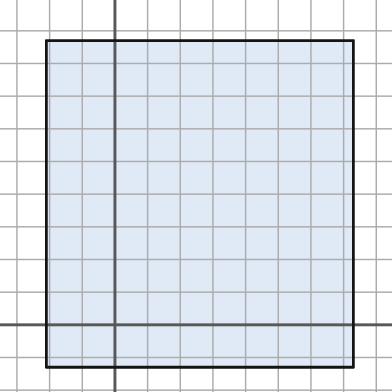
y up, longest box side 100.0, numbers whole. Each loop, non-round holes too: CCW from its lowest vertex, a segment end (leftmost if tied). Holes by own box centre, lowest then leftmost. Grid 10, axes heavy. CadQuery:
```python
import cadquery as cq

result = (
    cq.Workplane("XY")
    .moveTo(-21.0, -13.0)
    .lineTo(73.0, -13.0)
    .lineTo(73.0, 87.0)
    .lineTo(-21.0, 87.0)
    .close()
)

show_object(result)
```